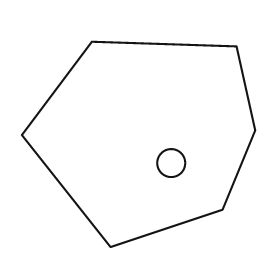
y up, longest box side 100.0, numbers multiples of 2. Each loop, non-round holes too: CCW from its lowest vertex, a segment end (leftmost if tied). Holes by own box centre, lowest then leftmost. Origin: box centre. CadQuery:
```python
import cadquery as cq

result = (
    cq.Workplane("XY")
    .moveTo(-12.0, -44.0)
    .lineTo(36.0, -28.0)
    .lineTo(50.0, 6.0)
    .lineTo(42.0, 42.0)
    .lineTo(-20.0, 44.0)
    .lineTo(-50.0, 4.0)
    .close()
    .moveTo(14.0, -8.0)
    .circle(6.0)
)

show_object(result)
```